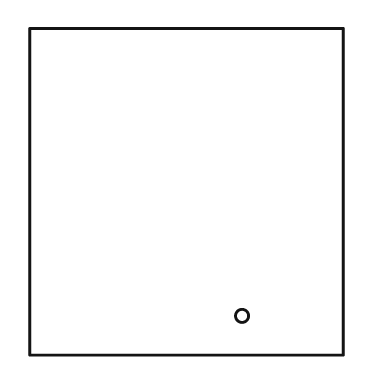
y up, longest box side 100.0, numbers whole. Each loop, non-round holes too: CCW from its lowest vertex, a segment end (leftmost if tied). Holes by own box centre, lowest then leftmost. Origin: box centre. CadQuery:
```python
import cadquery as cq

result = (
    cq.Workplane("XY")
    .moveTo(-48.0, -50.0)
    .lineTo(48.0, -50.0)
    .lineTo(48.0, 50.0)
    .lineTo(-48.0, 50.0)
    .close()
    .moveTo(17.0, -38.0)
    .circle(2.0)
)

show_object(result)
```